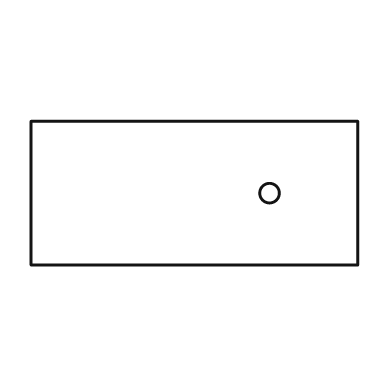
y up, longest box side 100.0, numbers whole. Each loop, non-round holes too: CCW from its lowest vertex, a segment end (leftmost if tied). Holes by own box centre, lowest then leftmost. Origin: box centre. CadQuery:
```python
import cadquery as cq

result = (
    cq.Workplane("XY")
    .moveTo(-50.0, -22.0)
    .lineTo(50.0, -22.0)
    .lineTo(50.0, 22.0)
    .lineTo(-50.0, 22.0)
    .close()
    .moveTo(23.0, 0.0)
    .circle(3.0)
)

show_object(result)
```